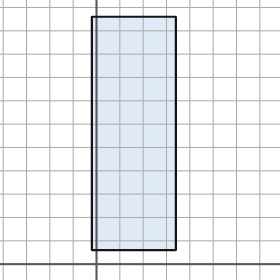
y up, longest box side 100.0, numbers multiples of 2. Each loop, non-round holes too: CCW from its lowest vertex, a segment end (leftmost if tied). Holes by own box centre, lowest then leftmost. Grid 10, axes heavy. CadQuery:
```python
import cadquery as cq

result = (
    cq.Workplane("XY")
    .moveTo(-2.0, 6.0)
    .lineTo(34.0, 6.0)
    .lineTo(34.0, 106.0)
    .lineTo(-2.0, 106.0)
    .close()
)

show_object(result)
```